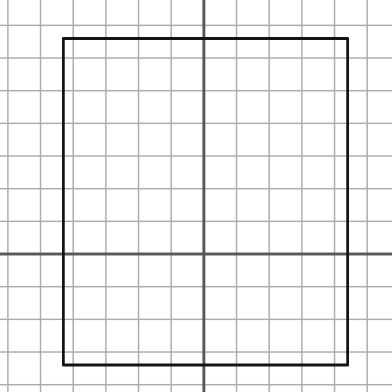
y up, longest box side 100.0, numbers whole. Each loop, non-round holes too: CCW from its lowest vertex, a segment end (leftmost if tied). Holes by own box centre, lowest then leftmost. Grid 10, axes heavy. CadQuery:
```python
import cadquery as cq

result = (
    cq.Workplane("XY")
    .moveTo(-43.0, -34.0)
    .lineTo(44.0, -34.0)
    .lineTo(44.0, 66.0)
    .lineTo(-43.0, 66.0)
    .close()
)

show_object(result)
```